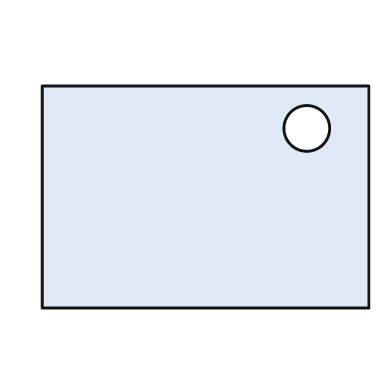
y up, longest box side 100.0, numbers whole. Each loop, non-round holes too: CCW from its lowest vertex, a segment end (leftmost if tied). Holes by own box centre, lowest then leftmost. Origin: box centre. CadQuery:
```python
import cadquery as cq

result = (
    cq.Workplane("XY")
    .moveTo(-50.0, -34.0)
    .lineTo(50.0, -34.0)
    .lineTo(50.0, 34.0)
    .lineTo(-50.0, 34.0)
    .close()
    .moveTo(31.0, 21.0)
    .circle(7.0)
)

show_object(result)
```